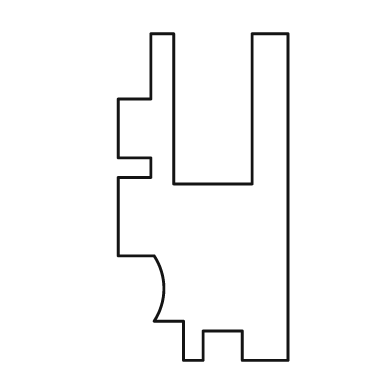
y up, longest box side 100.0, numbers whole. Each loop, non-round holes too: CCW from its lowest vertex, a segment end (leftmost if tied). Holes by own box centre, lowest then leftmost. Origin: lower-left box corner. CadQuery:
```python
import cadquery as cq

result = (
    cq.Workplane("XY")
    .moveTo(20.0, 0.0)
    .lineTo(26.0, 0.0)
    .lineTo(26.0, 9.0)
    .lineTo(38.0, 9.0)
    .lineTo(38.0, 0.0)
    .lineTo(52.0, 0.0)
    .lineTo(52.0, 100.0)
    .lineTo(41.0, 100.0)
    .lineTo(41.0, 54.0)
    .lineTo(17.0, 54.0)
    .lineTo(17.0, 100.0)
    .lineTo(10.0, 100.0)
    .lineTo(10.0, 80.0)
    .lineTo(0.0, 80.0)
    .lineTo(0.0, 62.0)
    .lineTo(10.0, 62.0)
    .lineTo(10.0, 56.0)
    .lineTo(0.0, 56.0)
    .lineTo(0.0, 32.0)
    .lineTo(11.0, 32.0)
    .threePointArc((14.0, 22.0), (11.0, 12.0))
    .lineTo(20.0, 12.0)
    .close()
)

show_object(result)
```